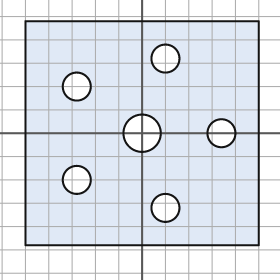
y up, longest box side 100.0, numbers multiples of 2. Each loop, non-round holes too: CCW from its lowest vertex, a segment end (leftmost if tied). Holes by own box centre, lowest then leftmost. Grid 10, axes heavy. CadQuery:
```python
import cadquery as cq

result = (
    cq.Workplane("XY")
    .moveTo(-50.0, -48.0)
    .lineTo(50.0, -48.0)
    .lineTo(50.0, 48.0)
    .lineTo(-50.0, 48.0)
    .close()
    .moveTo(10.0, -32.0)
    .circle(6.0)
    .moveTo(-28.0, -20.0)
    .circle(6.0)
    .moveTo(0.0, 0.0)
    .circle(8.0)
    .moveTo(34.0, 0.0)
    .circle(6.0)
    .moveTo(-28.0, 20.0)
    .circle(6.0)
    .moveTo(10.0, 32.0)
    .circle(6.0)
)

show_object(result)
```